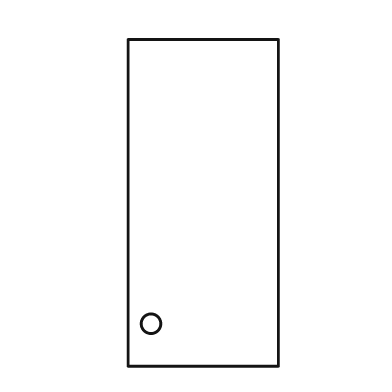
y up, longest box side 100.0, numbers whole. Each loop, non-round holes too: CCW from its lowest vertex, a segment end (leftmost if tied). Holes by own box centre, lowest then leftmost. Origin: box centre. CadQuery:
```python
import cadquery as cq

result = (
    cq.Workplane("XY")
    .moveTo(-23.0, -50.0)
    .lineTo(23.0, -50.0)
    .lineTo(23.0, 50.0)
    .lineTo(-23.0, 50.0)
    .close()
    .moveTo(-16.0, -37.0)
    .circle(3.0)
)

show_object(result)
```